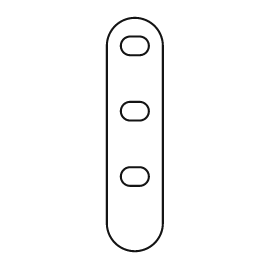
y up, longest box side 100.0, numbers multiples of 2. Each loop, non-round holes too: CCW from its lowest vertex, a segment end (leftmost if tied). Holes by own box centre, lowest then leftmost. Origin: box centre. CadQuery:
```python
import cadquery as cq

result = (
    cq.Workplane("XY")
    .moveTo(-12.0, -38.0)
    .threePointArc((0.0, -50.0), (12.0, -38.0))
    .lineTo(12.0, 38.0)
    .threePointArc((0.0, 50.0), (-12.0, 38.0))
    .close()
    .moveTo(-2.0, -22.0)
    .lineTo(2.0, -22.0)
    .threePointArc((6.0, -18.0), (2.0, -14.0))
    .lineTo(-2.0, -14.0)
    .threePointArc((-6.0, -18.0), (-2.0, -22.0))
    .close()
    .moveTo(-2.0, 6.0)
    .lineTo(2.0, 6.0)
    .threePointArc((6.0, 10.0), (2.0, 14.0))
    .lineTo(-2.0, 14.0)
    .threePointArc((-6.0, 10.0), (-2.0, 6.0))
    .close()
    .moveTo(-2.0, 34.0)
    .lineTo(2.0, 34.0)
    .threePointArc((6.0, 38.0), (2.0, 42.0))
    .lineTo(-2.0, 42.0)
    .threePointArc((-6.0, 38.0), (-2.0, 34.0))
    .close()
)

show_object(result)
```